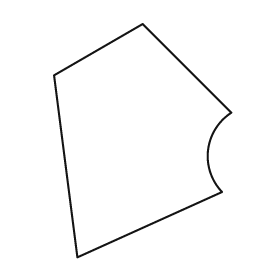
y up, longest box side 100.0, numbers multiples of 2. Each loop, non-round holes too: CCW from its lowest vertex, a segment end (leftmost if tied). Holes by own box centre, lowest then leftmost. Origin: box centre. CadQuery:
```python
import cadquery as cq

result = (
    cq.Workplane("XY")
    .moveTo(-28.0, -50.0)
    .lineTo(34.0, -22.0)
    .threePointArc((28.0, -4.0), (38.0, 12.0))
    .lineTo(0.0, 50.0)
    .lineTo(-38.0, 28.0)
    .close()
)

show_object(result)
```